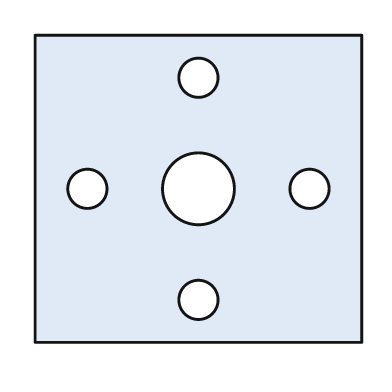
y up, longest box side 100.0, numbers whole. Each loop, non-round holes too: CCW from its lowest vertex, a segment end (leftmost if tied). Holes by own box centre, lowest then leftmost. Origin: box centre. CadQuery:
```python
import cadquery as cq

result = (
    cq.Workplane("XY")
    .moveTo(-50.0, -47.0)
    .lineTo(50.0, -47.0)
    .lineTo(50.0, 47.0)
    .lineTo(-50.0, 47.0)
    .close()
    .moveTo(0.0, -34.0)
    .circle(6.0)
    .moveTo(-34.0, 0.0)
    .circle(6.0)
    .moveTo(0.0, 0.0)
    .circle(11.0)
    .moveTo(34.0, 0.0)
    .circle(6.0)
    .moveTo(0.0, 34.0)
    .circle(6.0)
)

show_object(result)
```